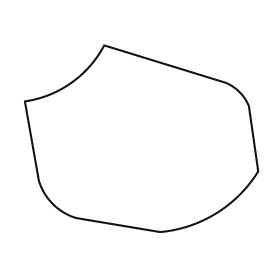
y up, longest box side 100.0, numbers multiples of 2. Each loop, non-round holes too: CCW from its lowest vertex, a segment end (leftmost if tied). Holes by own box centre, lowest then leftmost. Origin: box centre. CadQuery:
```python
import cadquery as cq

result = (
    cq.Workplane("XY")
    .moveTo(8.0, -40.0)
    .threePointArc((32.0, -32.0), (50.0, -14.0))
    .lineTo(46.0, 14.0)
    .threePointArc((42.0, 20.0), (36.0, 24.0))
    .lineTo(-16.0, 40.0)
    .threePointArc((-30.0, 24.0), (-50.0, 16.0))
    .lineTo(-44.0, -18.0)
    .threePointArc((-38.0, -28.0), (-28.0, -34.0))
    .close()
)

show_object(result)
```